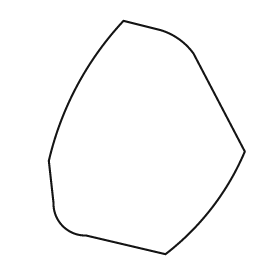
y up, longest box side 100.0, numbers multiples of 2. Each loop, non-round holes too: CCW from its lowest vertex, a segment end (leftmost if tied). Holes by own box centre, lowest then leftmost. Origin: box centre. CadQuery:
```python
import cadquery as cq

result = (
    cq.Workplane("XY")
    .moveTo(8.0, -50.0)
    .threePointArc((28.0, -30.0), (42.0, -6.0))
    .lineTo(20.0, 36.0)
    .threePointArc((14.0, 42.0), (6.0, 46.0))
    .lineTo(-10.0, 50.0)
    .threePointArc((-30.0, 22.0), (-42.0, -10.0))
    .lineTo(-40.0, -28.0)
    .threePointArc((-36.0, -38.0), (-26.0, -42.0))
    .close()
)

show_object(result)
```